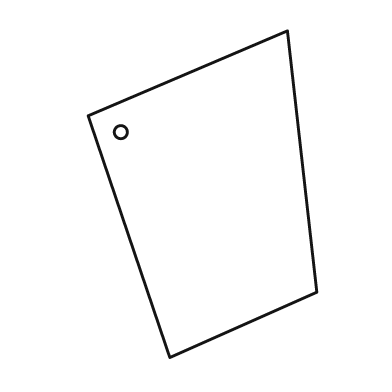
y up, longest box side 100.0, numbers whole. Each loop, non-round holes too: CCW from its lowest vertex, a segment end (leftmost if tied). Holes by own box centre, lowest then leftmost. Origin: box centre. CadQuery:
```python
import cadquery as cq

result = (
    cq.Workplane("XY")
    .moveTo(-10.0, -50.0)
    .lineTo(35.0, -30.0)
    .lineTo(26.0, 50.0)
    .lineTo(-35.0, 24.0)
    .close()
    .moveTo(-25.0, 19.0)
    .circle(2.0)
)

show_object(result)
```